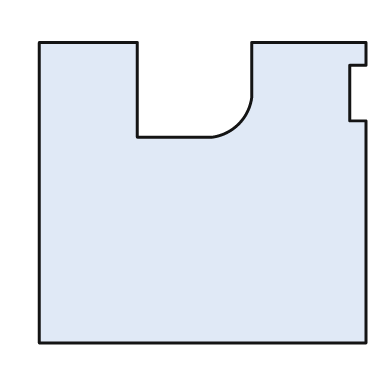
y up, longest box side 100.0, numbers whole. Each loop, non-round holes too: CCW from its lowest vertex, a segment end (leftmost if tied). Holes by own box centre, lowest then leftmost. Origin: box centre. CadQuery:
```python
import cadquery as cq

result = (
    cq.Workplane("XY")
    .moveTo(-50.0, -46.0)
    .lineTo(50.0, -46.0)
    .lineTo(50.0, 22.0)
    .lineTo(45.0, 22.0)
    .lineTo(45.0, 39.0)
    .lineTo(50.0, 39.0)
    .lineTo(50.0, 46.0)
    .lineTo(15.0, 46.0)
    .lineTo(15.0, 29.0)
    .threePointArc((11.0, 21.0), (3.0, 17.0))
    .lineTo(-20.0, 17.0)
    .lineTo(-20.0, 46.0)
    .lineTo(-50.0, 46.0)
    .close()
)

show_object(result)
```